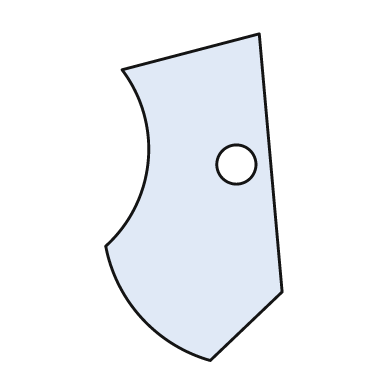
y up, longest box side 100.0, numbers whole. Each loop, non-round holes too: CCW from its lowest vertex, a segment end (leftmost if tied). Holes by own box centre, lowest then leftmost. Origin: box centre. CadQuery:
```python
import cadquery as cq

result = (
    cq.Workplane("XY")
    .moveTo(5.0, -50.0)
    .lineTo(27.0, -29.0)
    .lineTo(20.0, 50.0)
    .lineTo(-22.0, 39.0)
    .threePointArc((-14.0, 11.0), (-27.0, -15.0))
    .threePointArc((-16.0, -37.0), (5.0, -50.0))
    .close()
    .moveTo(13.0, 10.0)
    .circle(6.0)
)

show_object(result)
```